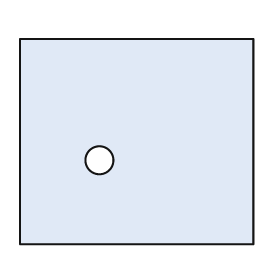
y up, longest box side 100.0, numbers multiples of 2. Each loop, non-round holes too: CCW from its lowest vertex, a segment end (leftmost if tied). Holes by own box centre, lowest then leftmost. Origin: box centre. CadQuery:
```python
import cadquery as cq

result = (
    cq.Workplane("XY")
    .moveTo(-50.0, -44.0)
    .lineTo(50.0, -44.0)
    .lineTo(50.0, 44.0)
    .lineTo(-50.0, 44.0)
    .close()
    .moveTo(-16.0, -8.0)
    .circle(6.0)
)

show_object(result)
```